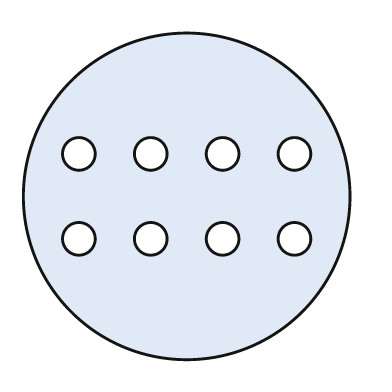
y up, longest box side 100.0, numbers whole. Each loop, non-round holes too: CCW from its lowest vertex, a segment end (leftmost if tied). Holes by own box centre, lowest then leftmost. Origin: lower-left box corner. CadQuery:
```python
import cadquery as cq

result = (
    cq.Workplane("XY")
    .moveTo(50.0, 50.0)
    .circle(50.0)
    .moveTo(17.0, 37.0)
    .circle(5.0)
    .moveTo(39.0, 37.0)
    .circle(5.0)
    .moveTo(61.0, 37.0)
    .circle(5.0)
    .moveTo(83.0, 37.0)
    .circle(5.0)
    .moveTo(17.0, 63.0)
    .circle(5.0)
    .moveTo(39.0, 63.0)
    .circle(5.0)
    .moveTo(61.0, 63.0)
    .circle(5.0)
    .moveTo(83.0, 63.0)
    .circle(5.0)
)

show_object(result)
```